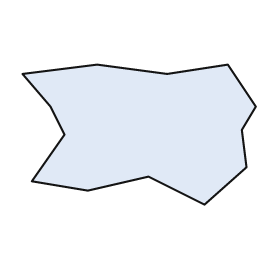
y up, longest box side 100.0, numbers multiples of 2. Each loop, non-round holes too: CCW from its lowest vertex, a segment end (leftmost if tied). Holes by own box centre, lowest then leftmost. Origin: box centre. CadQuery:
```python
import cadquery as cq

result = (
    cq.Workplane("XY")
    .moveTo(28.0, -30.0)
    .lineTo(46.0, -14.0)
    .lineTo(44.0, 2.0)
    .lineTo(50.0, 12.0)
    .lineTo(38.0, 30.0)
    .lineTo(12.0, 26.0)
    .lineTo(-18.0, 30.0)
    .lineTo(-50.0, 26.0)
    .lineTo(-38.0, 12.0)
    .lineTo(-32.0, 0.0)
    .lineTo(-46.0, -20.0)
    .lineTo(-22.0, -24.0)
    .lineTo(4.0, -18.0)
    .close()
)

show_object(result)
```